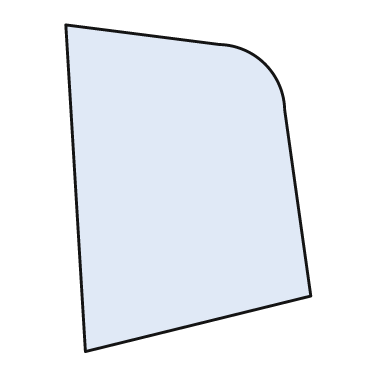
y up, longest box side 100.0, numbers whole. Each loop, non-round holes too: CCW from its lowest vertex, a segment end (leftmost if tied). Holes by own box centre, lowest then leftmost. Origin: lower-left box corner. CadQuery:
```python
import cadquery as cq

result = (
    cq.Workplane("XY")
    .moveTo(6.0, 0.0)
    .lineTo(75.0, 17.0)
    .lineTo(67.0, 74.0)
    .threePointArc((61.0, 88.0), (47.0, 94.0))
    .lineTo(0.0, 100.0)
    .close()
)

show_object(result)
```